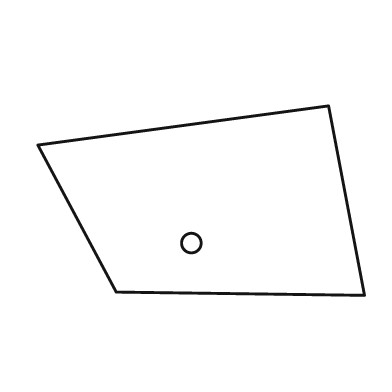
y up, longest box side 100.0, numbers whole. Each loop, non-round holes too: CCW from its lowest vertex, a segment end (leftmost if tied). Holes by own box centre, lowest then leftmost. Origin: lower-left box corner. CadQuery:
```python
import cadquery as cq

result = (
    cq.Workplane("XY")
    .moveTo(100.0, 0.0)
    .lineTo(89.0, 58.0)
    .lineTo(0.0, 46.0)
    .lineTo(24.0, 1.0)
    .close()
    .moveTo(47.0, 16.0)
    .circle(3.0)
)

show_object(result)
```